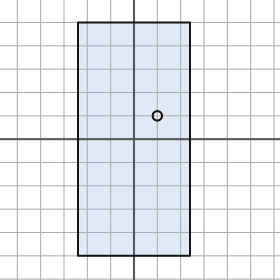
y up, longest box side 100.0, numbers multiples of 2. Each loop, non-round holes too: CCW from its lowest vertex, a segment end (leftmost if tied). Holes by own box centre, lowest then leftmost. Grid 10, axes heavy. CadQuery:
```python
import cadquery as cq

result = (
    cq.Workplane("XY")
    .moveTo(-24.0, -50.0)
    .lineTo(24.0, -50.0)
    .lineTo(24.0, 50.0)
    .lineTo(-24.0, 50.0)
    .close()
    .moveTo(10.0, 10.0)
    .circle(2.0)
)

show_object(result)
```